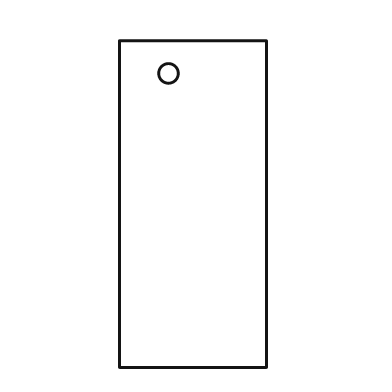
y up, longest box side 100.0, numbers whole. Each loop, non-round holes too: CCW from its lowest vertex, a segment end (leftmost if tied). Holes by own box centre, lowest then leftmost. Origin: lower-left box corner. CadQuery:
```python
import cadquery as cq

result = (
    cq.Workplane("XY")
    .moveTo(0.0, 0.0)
    .lineTo(45.0, 0.0)
    .lineTo(45.0, 100.0)
    .lineTo(0.0, 100.0)
    .close()
    .moveTo(15.0, 90.0)
    .circle(3.0)
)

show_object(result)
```